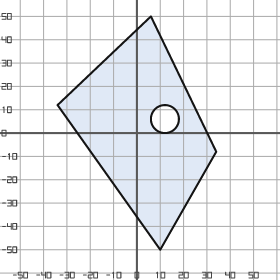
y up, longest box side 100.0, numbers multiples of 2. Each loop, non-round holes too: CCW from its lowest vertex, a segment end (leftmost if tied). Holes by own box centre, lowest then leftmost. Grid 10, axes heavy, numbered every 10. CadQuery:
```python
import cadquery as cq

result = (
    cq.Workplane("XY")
    .moveTo(10.0, -50.0)
    .lineTo(34.0, -8.0)
    .lineTo(6.0, 50.0)
    .lineTo(-34.0, 12.0)
    .close()
    .moveTo(12.0, 6.0)
    .circle(6.0)
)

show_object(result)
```